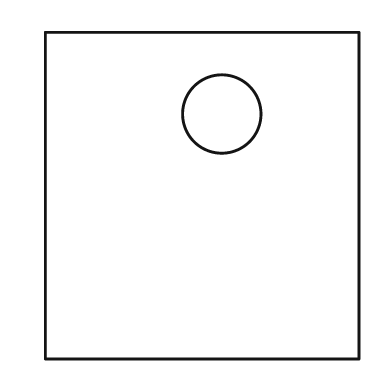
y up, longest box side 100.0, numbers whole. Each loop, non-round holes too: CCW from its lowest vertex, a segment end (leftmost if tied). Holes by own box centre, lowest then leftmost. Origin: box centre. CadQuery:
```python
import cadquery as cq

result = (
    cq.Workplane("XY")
    .moveTo(-48.0, -50.0)
    .lineTo(48.0, -50.0)
    .lineTo(48.0, 50.0)
    .lineTo(-48.0, 50.0)
    .close()
    .moveTo(6.0, 25.0)
    .circle(12.0)
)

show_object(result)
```